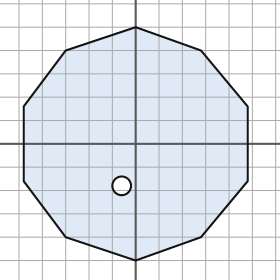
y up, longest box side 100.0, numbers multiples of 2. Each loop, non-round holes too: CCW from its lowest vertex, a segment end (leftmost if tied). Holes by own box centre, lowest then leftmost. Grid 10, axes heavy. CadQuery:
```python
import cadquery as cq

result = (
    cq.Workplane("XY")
    .moveTo(0.0, -50.0)
    .lineTo(28.0, -40.0)
    .lineTo(48.0, -16.0)
    .lineTo(48.0, 16.0)
    .lineTo(28.0, 40.0)
    .lineTo(0.0, 50.0)
    .lineTo(-30.0, 40.0)
    .lineTo(-48.0, 16.0)
    .lineTo(-48.0, -16.0)
    .lineTo(-30.0, -40.0)
    .close()
    .moveTo(-6.0, -18.0)
    .circle(4.0)
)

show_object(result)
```